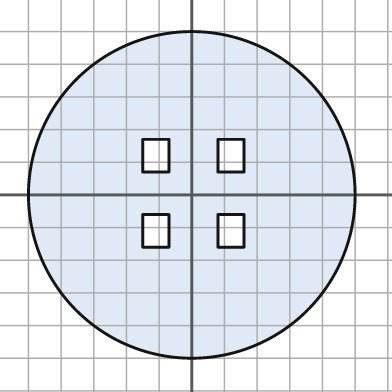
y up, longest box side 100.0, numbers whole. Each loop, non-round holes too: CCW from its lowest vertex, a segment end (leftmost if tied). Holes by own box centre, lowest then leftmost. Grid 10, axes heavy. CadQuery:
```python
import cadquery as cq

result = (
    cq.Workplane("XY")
    .moveTo(0.0, 0.0)
    .circle(50.0)
    .moveTo(-15.0, -16.0)
    .lineTo(-7.0, -16.0)
    .lineTo(-7.0, -6.0)
    .lineTo(-15.0, -6.0)
    .close()
    .moveTo(8.0, -16.0)
    .lineTo(16.0, -16.0)
    .lineTo(16.0, -6.0)
    .lineTo(8.0, -6.0)
    .close()
    .moveTo(-15.0, 7.0)
    .lineTo(-7.0, 7.0)
    .lineTo(-7.0, 17.0)
    .lineTo(-15.0, 17.0)
    .close()
    .moveTo(8.0, 7.0)
    .lineTo(16.0, 7.0)
    .lineTo(16.0, 17.0)
    .lineTo(8.0, 17.0)
    .close()
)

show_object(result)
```